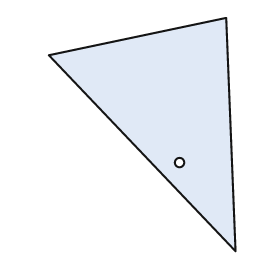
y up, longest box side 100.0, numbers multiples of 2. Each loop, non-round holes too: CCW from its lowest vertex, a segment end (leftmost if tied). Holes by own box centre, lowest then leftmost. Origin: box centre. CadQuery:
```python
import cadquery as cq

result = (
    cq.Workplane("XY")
    .moveTo(40.0, -50.0)
    .lineTo(36.0, 50.0)
    .lineTo(-40.0, 34.0)
    .close()
    .moveTo(16.0, -12.0)
    .circle(2.0)
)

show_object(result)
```